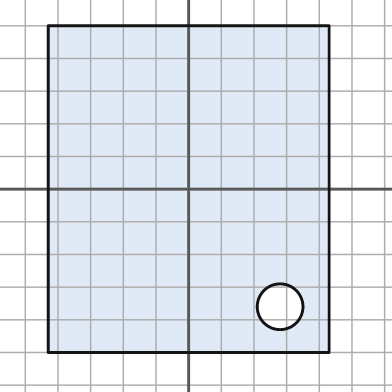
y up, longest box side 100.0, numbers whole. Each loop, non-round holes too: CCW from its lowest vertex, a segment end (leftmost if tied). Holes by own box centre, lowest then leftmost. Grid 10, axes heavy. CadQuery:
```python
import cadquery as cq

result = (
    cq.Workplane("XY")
    .moveTo(-43.0, -50.0)
    .lineTo(43.0, -50.0)
    .lineTo(43.0, 50.0)
    .lineTo(-43.0, 50.0)
    .close()
    .moveTo(28.0, -36.0)
    .circle(7.0)
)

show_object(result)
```